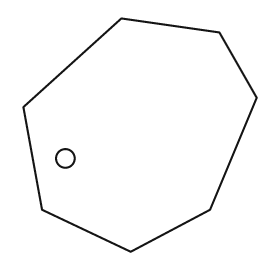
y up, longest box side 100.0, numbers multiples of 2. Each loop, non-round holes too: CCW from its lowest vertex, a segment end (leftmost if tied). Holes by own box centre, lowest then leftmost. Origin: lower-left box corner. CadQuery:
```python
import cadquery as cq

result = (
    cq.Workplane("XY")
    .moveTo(46.0, 0.0)
    .lineTo(80.0, 18.0)
    .lineTo(100.0, 66.0)
    .lineTo(84.0, 94.0)
    .lineTo(42.0, 100.0)
    .lineTo(0.0, 62.0)
    .lineTo(8.0, 18.0)
    .close()
    .moveTo(18.0, 40.0)
    .circle(4.0)
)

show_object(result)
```